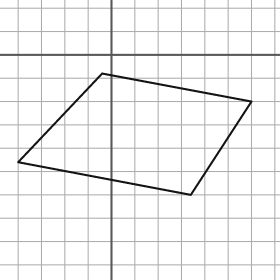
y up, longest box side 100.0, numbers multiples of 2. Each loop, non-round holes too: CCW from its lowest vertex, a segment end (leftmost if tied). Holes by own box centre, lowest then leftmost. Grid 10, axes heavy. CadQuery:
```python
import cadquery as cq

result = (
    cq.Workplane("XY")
    .moveTo(34.0, -60.0)
    .lineTo(60.0, -20.0)
    .lineTo(-4.0, -8.0)
    .lineTo(-40.0, -46.0)
    .close()
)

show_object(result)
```